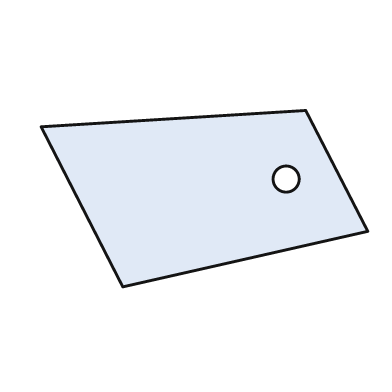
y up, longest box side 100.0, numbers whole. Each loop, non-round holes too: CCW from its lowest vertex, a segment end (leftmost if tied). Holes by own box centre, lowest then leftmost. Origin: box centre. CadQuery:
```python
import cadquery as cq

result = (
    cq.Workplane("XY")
    .moveTo(-25.0, -27.0)
    .lineTo(50.0, -10.0)
    .lineTo(31.0, 27.0)
    .lineTo(-50.0, 22.0)
    .close()
    .moveTo(25.0, 6.0)
    .circle(4.0)
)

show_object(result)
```